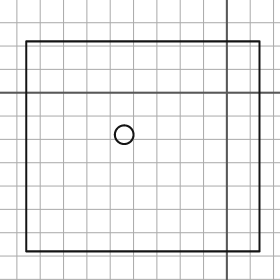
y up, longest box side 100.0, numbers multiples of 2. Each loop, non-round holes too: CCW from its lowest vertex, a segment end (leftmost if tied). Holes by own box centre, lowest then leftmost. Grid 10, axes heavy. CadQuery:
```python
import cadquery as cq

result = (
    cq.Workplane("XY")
    .moveTo(-86.0, -68.0)
    .lineTo(14.0, -68.0)
    .lineTo(14.0, 22.0)
    .lineTo(-86.0, 22.0)
    .close()
    .moveTo(-44.0, -18.0)
    .circle(4.0)
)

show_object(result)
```